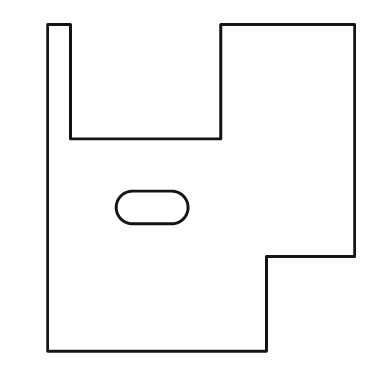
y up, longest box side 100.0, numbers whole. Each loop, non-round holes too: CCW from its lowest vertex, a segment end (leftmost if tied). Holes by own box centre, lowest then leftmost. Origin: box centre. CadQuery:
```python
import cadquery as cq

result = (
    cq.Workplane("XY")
    .moveTo(-47.0, -50.0)
    .lineTo(20.0, -50.0)
    .lineTo(20.0, -21.0)
    .lineTo(47.0, -21.0)
    .lineTo(47.0, 50.0)
    .lineTo(6.0, 50.0)
    .lineTo(6.0, 15.0)
    .lineTo(-40.0, 15.0)
    .lineTo(-40.0, 50.0)
    .lineTo(-47.0, 50.0)
    .close()
    .moveTo(-21.0, -11.0)
    .lineTo(-9.0, -11.0)
    .threePointArc((-4.0, -6.0), (-9.0, -1.0))
    .lineTo(-21.0, -1.0)
    .threePointArc((-26.0, -6.0), (-21.0, -11.0))
    .close()
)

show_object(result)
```